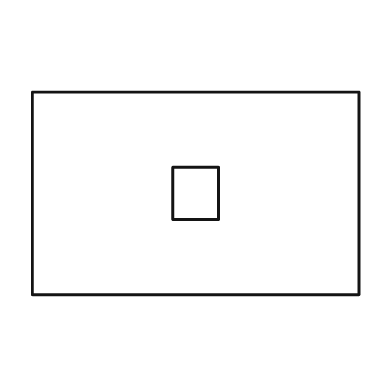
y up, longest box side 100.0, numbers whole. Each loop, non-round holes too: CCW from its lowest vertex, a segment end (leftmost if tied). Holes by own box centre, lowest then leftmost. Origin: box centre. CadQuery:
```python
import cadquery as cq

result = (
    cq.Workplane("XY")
    .moveTo(-50.0, -31.0)
    .lineTo(50.0, -31.0)
    .lineTo(50.0, 31.0)
    .lineTo(-50.0, 31.0)
    .close()
    .moveTo(-7.0, -8.0)
    .lineTo(7.0, -8.0)
    .lineTo(7.0, 8.0)
    .lineTo(-7.0, 8.0)
    .close()
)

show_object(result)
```